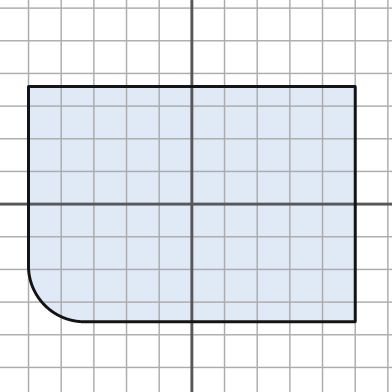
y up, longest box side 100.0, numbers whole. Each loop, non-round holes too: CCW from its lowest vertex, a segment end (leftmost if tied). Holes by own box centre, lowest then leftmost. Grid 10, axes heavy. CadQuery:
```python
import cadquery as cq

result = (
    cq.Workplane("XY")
    .moveTo(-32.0, -36.0)
    .lineTo(50.0, -36.0)
    .lineTo(50.0, 36.0)
    .lineTo(-50.0, 36.0)
    .lineTo(-50.0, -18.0)
    .threePointArc((-45.0, -31.0), (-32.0, -36.0))
    .close()
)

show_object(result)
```